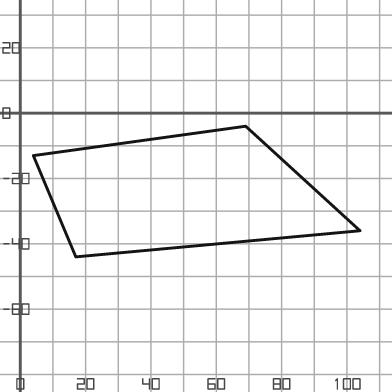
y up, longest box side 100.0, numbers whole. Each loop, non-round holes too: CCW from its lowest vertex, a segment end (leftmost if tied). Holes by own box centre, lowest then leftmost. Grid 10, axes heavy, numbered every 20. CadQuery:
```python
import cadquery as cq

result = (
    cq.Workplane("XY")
    .moveTo(17.0, -44.0)
    .lineTo(104.0, -36.0)
    .lineTo(69.0, -4.0)
    .lineTo(4.0, -13.0)
    .close()
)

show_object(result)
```